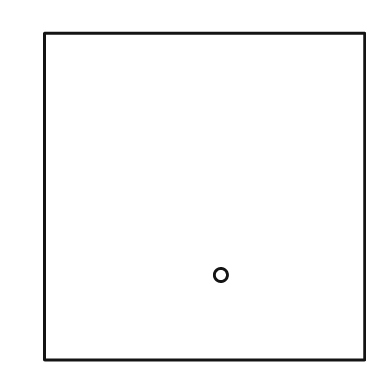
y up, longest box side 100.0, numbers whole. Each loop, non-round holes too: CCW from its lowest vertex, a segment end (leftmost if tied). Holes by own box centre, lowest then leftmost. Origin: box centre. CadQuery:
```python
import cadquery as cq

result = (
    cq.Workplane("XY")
    .moveTo(-49.0, -50.0)
    .lineTo(49.0, -50.0)
    .lineTo(49.0, 50.0)
    .lineTo(-49.0, 50.0)
    .close()
    .moveTo(5.0, -24.0)
    .circle(2.0)
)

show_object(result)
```